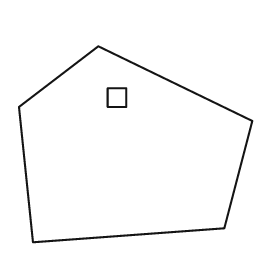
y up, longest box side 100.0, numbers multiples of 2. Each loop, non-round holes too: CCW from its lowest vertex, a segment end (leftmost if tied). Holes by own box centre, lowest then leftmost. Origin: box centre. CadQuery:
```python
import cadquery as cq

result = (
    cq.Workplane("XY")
    .moveTo(-44.0, -42.0)
    .lineTo(38.0, -36.0)
    .lineTo(50.0, 10.0)
    .lineTo(-16.0, 42.0)
    .lineTo(-50.0, 16.0)
    .close()
    .moveTo(-12.0, 16.0)
    .lineTo(-4.0, 16.0)
    .lineTo(-4.0, 24.0)
    .lineTo(-12.0, 24.0)
    .close()
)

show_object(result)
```